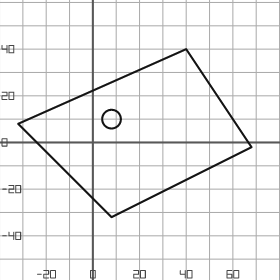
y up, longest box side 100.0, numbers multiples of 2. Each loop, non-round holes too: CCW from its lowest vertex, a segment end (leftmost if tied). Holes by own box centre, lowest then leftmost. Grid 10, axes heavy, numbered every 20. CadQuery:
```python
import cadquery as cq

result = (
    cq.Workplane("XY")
    .moveTo(8.0, -32.0)
    .lineTo(68.0, -2.0)
    .lineTo(40.0, 40.0)
    .lineTo(-32.0, 8.0)
    .close()
    .moveTo(8.0, 10.0)
    .circle(4.0)
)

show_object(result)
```